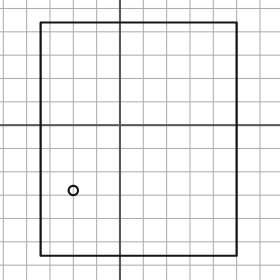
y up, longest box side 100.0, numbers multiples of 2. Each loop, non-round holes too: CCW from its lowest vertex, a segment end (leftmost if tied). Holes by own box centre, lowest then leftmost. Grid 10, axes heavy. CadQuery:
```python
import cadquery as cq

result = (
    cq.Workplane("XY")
    .moveTo(-34.0, -56.0)
    .lineTo(50.0, -56.0)
    .lineTo(50.0, 44.0)
    .lineTo(-34.0, 44.0)
    .close()
    .moveTo(-20.0, -28.0)
    .circle(2.0)
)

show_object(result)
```